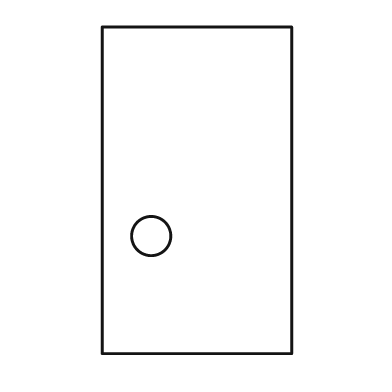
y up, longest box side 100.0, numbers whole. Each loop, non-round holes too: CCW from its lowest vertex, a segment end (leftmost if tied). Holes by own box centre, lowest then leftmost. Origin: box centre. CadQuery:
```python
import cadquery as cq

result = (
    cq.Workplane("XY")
    .moveTo(-29.0, -50.0)
    .lineTo(29.0, -50.0)
    .lineTo(29.0, 50.0)
    .lineTo(-29.0, 50.0)
    .close()
    .moveTo(-14.0, -14.0)
    .circle(6.0)
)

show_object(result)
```